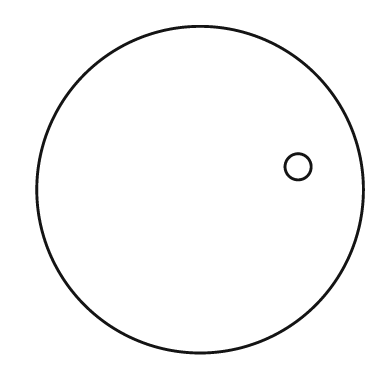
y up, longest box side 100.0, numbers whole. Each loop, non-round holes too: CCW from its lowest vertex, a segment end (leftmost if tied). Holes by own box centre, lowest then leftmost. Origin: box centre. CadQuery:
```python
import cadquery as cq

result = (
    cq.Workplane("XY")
    .moveTo(0.0, 0.0)
    .circle(50.0)
    .moveTo(30.0, 7.0)
    .circle(4.0)
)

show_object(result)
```